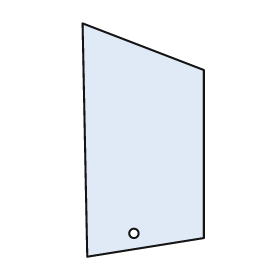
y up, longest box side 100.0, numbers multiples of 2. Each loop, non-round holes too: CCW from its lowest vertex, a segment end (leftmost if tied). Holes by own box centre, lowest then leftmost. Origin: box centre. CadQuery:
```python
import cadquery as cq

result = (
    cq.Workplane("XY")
    .moveTo(-24.0, -50.0)
    .lineTo(26.0, -42.0)
    .lineTo(26.0, 30.0)
    .lineTo(-26.0, 50.0)
    .close()
    .moveTo(-4.0, -40.0)
    .circle(2.0)
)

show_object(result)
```